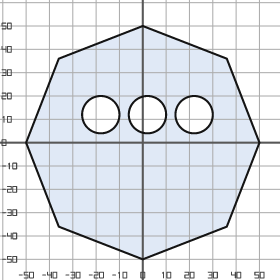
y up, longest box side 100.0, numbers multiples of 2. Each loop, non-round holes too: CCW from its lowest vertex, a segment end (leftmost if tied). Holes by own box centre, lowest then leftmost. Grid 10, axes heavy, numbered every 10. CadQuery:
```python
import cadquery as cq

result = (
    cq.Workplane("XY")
    .moveTo(0.0, -50.0)
    .lineTo(36.0, -36.0)
    .lineTo(50.0, 0.0)
    .lineTo(36.0, 36.0)
    .lineTo(0.0, 50.0)
    .lineTo(-36.0, 36.0)
    .lineTo(-50.0, 0.0)
    .lineTo(-36.0, -36.0)
    .close()
    .moveTo(-18.0, 12.0)
    .circle(8.0)
    .moveTo(2.0, 12.0)
    .circle(8.0)
    .moveTo(22.0, 12.0)
    .circle(8.0)
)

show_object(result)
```